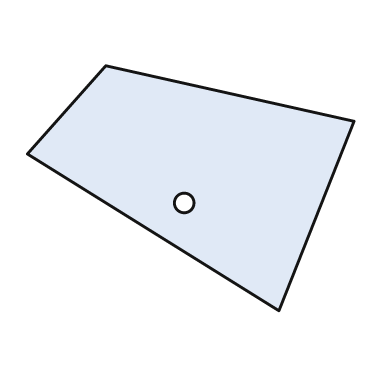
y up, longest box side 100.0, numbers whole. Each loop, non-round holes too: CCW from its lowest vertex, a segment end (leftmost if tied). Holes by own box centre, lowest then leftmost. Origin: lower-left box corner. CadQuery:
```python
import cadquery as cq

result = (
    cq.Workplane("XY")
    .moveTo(77.0, 0.0)
    .lineTo(100.0, 58.0)
    .lineTo(24.0, 75.0)
    .lineTo(0.0, 48.0)
    .close()
    .moveTo(48.0, 33.0)
    .circle(3.0)
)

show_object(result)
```